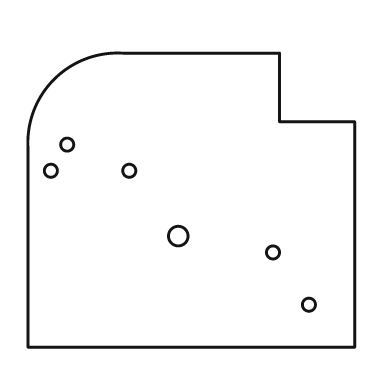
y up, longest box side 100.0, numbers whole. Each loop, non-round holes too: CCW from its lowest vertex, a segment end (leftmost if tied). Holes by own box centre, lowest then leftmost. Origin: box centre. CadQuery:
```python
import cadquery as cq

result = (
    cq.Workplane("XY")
    .moveTo(-50.0, -45.0)
    .lineTo(50.0, -45.0)
    .lineTo(50.0, 24.0)
    .lineTo(27.0, 24.0)
    .lineTo(27.0, 45.0)
    .lineTo(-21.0, 45.0)
    .threePointArc((-42.0, 37.0), (-50.0, 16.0))
    .close()
    .moveTo(36.0, -32.0)
    .circle(2.0)
    .moveTo(25.0, -16.0)
    .circle(2.0)
    .moveTo(-4.0, -11.0)
    .circle(3.0)
    .moveTo(-43.0, 9.0)
    .circle(2.0)
    .moveTo(-19.0, 9.0)
    .circle(2.0)
    .moveTo(-38.0, 17.0)
    .circle(2.0)
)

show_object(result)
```